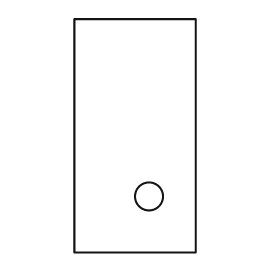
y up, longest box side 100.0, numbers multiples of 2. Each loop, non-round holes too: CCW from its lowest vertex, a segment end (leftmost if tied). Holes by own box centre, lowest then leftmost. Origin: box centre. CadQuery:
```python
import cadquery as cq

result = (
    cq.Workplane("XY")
    .moveTo(-26.0, -50.0)
    .lineTo(26.0, -50.0)
    .lineTo(26.0, 50.0)
    .lineTo(-26.0, 50.0)
    .close()
    .moveTo(6.0, -26.0)
    .circle(6.0)
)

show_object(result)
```